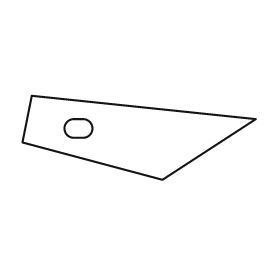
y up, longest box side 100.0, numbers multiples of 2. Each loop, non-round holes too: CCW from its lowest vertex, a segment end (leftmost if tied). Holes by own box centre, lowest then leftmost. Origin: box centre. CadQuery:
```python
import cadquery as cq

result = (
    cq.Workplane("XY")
    .moveTo(10.0, -18.0)
    .lineTo(50.0, 8.0)
    .lineTo(-46.0, 18.0)
    .lineTo(-50.0, -2.0)
    .close()
    .moveTo(-28.0, 0.0)
    .lineTo(-24.0, 0.0)
    .threePointArc((-20.0, 4.0), (-24.0, 8.0))
    .lineTo(-28.0, 8.0)
    .threePointArc((-32.0, 4.0), (-28.0, 0.0))
    .close()
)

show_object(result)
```